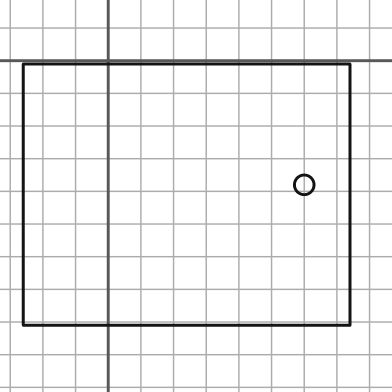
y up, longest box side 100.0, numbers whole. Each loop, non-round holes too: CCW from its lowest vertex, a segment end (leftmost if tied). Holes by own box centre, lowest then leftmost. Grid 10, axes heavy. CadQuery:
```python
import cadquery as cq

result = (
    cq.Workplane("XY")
    .moveTo(-26.0, -81.0)
    .lineTo(74.0, -81.0)
    .lineTo(74.0, -1.0)
    .lineTo(-26.0, -1.0)
    .close()
    .moveTo(60.0, -38.0)
    .circle(3.0)
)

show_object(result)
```